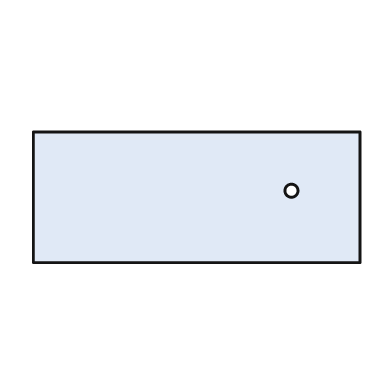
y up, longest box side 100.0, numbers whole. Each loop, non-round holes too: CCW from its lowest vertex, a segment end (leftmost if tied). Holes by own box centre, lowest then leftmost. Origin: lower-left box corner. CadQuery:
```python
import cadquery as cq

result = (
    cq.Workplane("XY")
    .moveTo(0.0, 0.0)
    .lineTo(100.0, 0.0)
    .lineTo(100.0, 40.0)
    .lineTo(0.0, 40.0)
    .close()
    .moveTo(79.0, 22.0)
    .circle(2.0)
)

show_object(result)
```